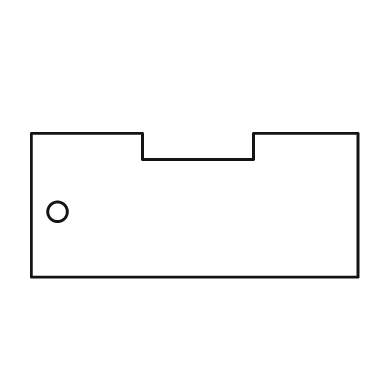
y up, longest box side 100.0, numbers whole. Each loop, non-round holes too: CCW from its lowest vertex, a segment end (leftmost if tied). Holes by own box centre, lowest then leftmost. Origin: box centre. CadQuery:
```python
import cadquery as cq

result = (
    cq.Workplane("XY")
    .moveTo(-50.0, -22.0)
    .lineTo(50.0, -22.0)
    .lineTo(50.0, 22.0)
    .lineTo(18.0, 22.0)
    .lineTo(18.0, 14.0)
    .lineTo(-16.0, 14.0)
    .lineTo(-16.0, 22.0)
    .lineTo(-50.0, 22.0)
    .close()
    .moveTo(-42.0, -2.0)
    .circle(3.0)
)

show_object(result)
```